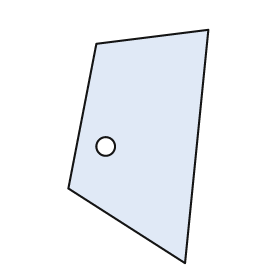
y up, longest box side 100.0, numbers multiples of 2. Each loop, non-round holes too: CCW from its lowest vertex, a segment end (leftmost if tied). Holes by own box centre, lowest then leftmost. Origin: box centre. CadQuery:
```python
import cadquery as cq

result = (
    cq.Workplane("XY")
    .moveTo(20.0, -50.0)
    .lineTo(30.0, 50.0)
    .lineTo(-18.0, 44.0)
    .lineTo(-30.0, -18.0)
    .close()
    .moveTo(-14.0, 0.0)
    .circle(4.0)
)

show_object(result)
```